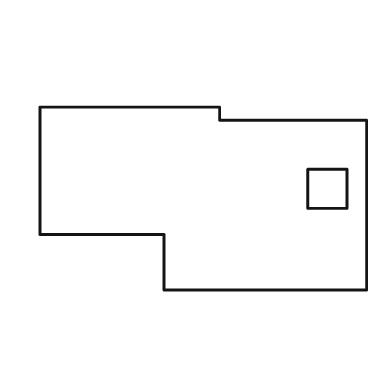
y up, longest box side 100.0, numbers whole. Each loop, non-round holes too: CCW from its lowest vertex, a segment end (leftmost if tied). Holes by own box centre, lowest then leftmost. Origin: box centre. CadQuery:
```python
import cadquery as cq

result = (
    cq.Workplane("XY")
    .moveTo(-12.0, -28.0)
    .lineTo(50.0, -28.0)
    .lineTo(50.0, 24.0)
    .lineTo(5.0, 24.0)
    .lineTo(5.0, 28.0)
    .lineTo(-50.0, 28.0)
    .lineTo(-50.0, -11.0)
    .lineTo(-12.0, -11.0)
    .close()
    .moveTo(32.0, -3.0)
    .lineTo(44.0, -3.0)
    .lineTo(44.0, 9.0)
    .lineTo(32.0, 9.0)
    .close()
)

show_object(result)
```